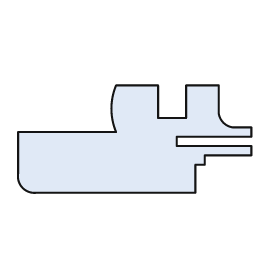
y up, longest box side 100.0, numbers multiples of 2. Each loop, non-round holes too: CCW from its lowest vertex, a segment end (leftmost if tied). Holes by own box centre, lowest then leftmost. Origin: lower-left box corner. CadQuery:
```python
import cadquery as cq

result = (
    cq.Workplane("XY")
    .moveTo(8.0, 0.0)
    .lineTo(76.0, 0.0)
    .lineTo(76.0, 12.0)
    .lineTo(80.0, 12.0)
    .lineTo(80.0, 16.0)
    .lineTo(100.0, 16.0)
    .lineTo(100.0, 20.0)
    .lineTo(68.0, 20.0)
    .lineTo(68.0, 24.0)
    .lineTo(100.0, 24.0)
    .lineTo(100.0, 28.0)
    .lineTo(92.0, 28.0)
    .threePointArc((88.0, 30.0), (86.0, 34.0))
    .lineTo(86.0, 46.0)
    .lineTo(72.0, 46.0)
    .lineTo(72.0, 32.0)
    .lineTo(60.0, 32.0)
    .lineTo(60.0, 46.0)
    .lineTo(42.0, 46.0)
    .threePointArc((40.0, 36.0), (42.0, 26.0))
    .lineTo(0.0, 26.0)
    .lineTo(0.0, 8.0)
    .threePointArc((2.0, 2.0), (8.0, 0.0))
    .close()
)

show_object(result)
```